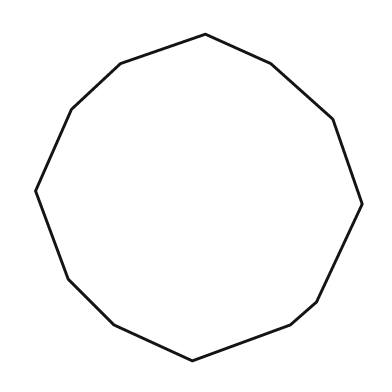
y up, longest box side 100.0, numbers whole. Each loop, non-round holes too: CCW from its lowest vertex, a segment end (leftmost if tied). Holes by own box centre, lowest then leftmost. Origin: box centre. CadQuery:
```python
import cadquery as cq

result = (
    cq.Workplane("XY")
    .moveTo(-2.0, -50.0)
    .lineTo(28.0, -39.0)
    .lineTo(36.0, -32.0)
    .lineTo(50.0, -2.0)
    .lineTo(41.0, 24.0)
    .lineTo(22.0, 41.0)
    .lineTo(2.0, 50.0)
    .lineTo(-24.0, 41.0)
    .lineTo(-39.0, 27.0)
    .lineTo(-50.0, 2.0)
    .lineTo(-40.0, -25.0)
    .lineTo(-26.0, -39.0)
    .close()
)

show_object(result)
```